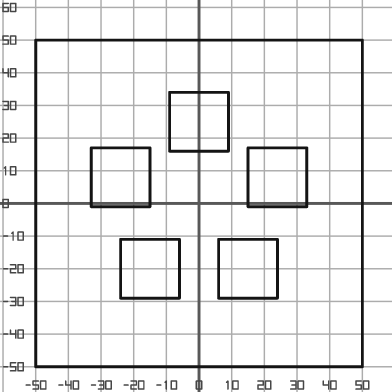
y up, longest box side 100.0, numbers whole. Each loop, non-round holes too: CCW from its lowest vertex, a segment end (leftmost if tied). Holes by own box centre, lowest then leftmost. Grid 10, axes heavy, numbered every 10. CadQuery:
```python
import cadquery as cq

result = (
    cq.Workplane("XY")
    .moveTo(-50.0, -50.0)
    .lineTo(50.0, -50.0)
    .lineTo(50.0, 50.0)
    .lineTo(-50.0, 50.0)
    .close()
    .moveTo(-24.0, -29.0)
    .lineTo(-6.0, -29.0)
    .lineTo(-6.0, -11.0)
    .lineTo(-24.0, -11.0)
    .close()
    .moveTo(6.0, -29.0)
    .lineTo(24.0, -29.0)
    .lineTo(24.0, -11.0)
    .lineTo(6.0, -11.0)
    .close()
    .moveTo(-33.0, -1.0)
    .lineTo(-15.0, -1.0)
    .lineTo(-15.0, 17.0)
    .lineTo(-33.0, 17.0)
    .close()
    .moveTo(15.0, -1.0)
    .lineTo(33.0, -1.0)
    .lineTo(33.0, 17.0)
    .lineTo(15.0, 17.0)
    .close()
    .moveTo(-9.0, 16.0)
    .lineTo(9.0, 16.0)
    .lineTo(9.0, 34.0)
    .lineTo(-9.0, 34.0)
    .close()
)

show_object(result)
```